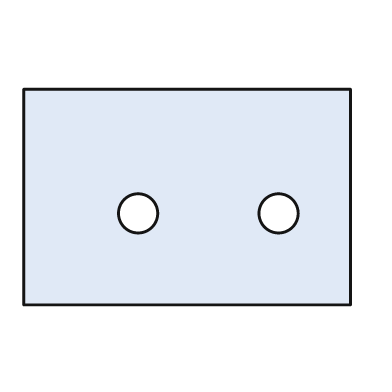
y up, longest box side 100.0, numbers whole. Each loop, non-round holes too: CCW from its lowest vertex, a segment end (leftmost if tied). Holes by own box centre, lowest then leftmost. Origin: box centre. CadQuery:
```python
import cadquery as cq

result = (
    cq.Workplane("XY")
    .moveTo(-50.0, -33.0)
    .lineTo(50.0, -33.0)
    .lineTo(50.0, 33.0)
    .lineTo(-50.0, 33.0)
    .close()
    .moveTo(-15.0, -5.0)
    .circle(6.0)
    .moveTo(28.0, -5.0)
    .circle(6.0)
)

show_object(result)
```